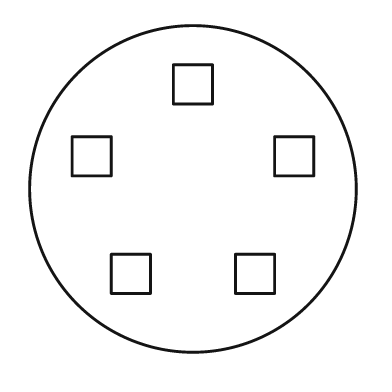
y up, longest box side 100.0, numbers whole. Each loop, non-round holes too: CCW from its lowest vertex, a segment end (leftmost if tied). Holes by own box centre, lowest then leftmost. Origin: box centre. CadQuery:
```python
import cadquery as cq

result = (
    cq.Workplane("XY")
    .moveTo(0.0, 0.0)
    .circle(50.0)
    .moveTo(-25.0, -32.0)
    .lineTo(-13.0, -32.0)
    .lineTo(-13.0, -20.0)
    .lineTo(-25.0, -20.0)
    .close()
    .moveTo(13.0, -32.0)
    .lineTo(25.0, -32.0)
    .lineTo(25.0, -20.0)
    .lineTo(13.0, -20.0)
    .close()
    .moveTo(-37.0, 4.0)
    .lineTo(-25.0, 4.0)
    .lineTo(-25.0, 16.0)
    .lineTo(-37.0, 16.0)
    .close()
    .moveTo(25.0, 4.0)
    .lineTo(37.0, 4.0)
    .lineTo(37.0, 16.0)
    .lineTo(25.0, 16.0)
    .close()
    .moveTo(-6.0, 26.0)
    .lineTo(6.0, 26.0)
    .lineTo(6.0, 38.0)
    .lineTo(-6.0, 38.0)
    .close()
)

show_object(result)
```